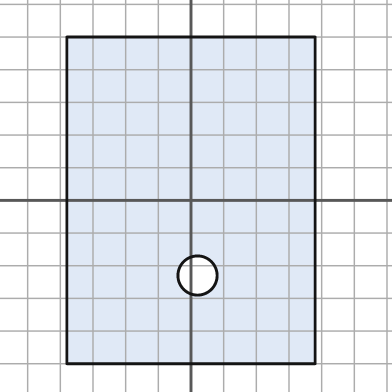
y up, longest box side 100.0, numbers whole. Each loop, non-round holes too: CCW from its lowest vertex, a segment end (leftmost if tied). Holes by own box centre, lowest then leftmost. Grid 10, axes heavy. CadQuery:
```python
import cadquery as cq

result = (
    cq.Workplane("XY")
    .moveTo(-38.0, -50.0)
    .lineTo(38.0, -50.0)
    .lineTo(38.0, 50.0)
    .lineTo(-38.0, 50.0)
    .close()
    .moveTo(2.0, -23.0)
    .circle(6.0)
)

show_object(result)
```